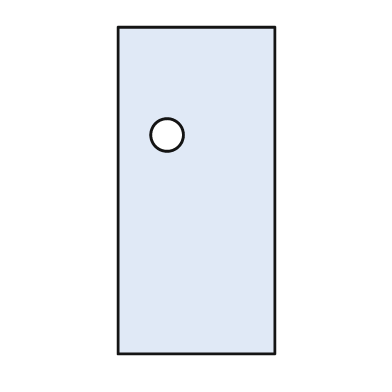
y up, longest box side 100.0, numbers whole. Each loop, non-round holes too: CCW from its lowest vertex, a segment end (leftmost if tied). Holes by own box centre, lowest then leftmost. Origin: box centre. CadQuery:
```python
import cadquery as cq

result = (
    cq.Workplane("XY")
    .moveTo(-24.0, -50.0)
    .lineTo(24.0, -50.0)
    .lineTo(24.0, 50.0)
    .lineTo(-24.0, 50.0)
    .close()
    .moveTo(-9.0, 17.0)
    .circle(5.0)
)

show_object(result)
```